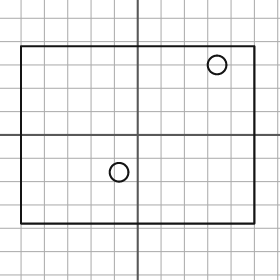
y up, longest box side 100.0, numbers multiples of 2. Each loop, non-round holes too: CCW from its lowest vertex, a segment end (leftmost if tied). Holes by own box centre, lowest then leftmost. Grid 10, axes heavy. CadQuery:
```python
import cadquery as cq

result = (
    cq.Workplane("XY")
    .moveTo(-50.0, -38.0)
    .lineTo(50.0, -38.0)
    .lineTo(50.0, 38.0)
    .lineTo(-50.0, 38.0)
    .close()
    .moveTo(-8.0, -16.0)
    .circle(4.0)
    .moveTo(34.0, 30.0)
    .circle(4.0)
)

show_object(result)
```